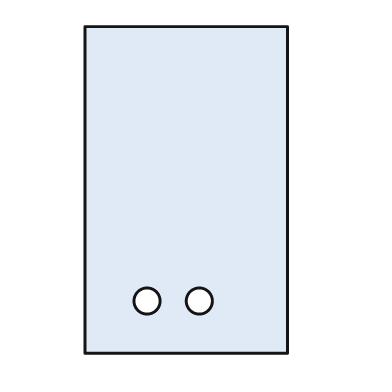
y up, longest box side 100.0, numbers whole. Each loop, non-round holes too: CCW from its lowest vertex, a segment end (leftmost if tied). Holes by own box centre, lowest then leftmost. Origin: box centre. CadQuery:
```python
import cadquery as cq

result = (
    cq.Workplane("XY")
    .moveTo(-31.0, -50.0)
    .lineTo(31.0, -50.0)
    .lineTo(31.0, 50.0)
    .lineTo(-31.0, 50.0)
    .close()
    .moveTo(-12.0, -34.0)
    .circle(4.0)
    .moveTo(4.0, -34.0)
    .circle(4.0)
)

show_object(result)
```